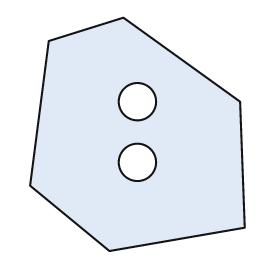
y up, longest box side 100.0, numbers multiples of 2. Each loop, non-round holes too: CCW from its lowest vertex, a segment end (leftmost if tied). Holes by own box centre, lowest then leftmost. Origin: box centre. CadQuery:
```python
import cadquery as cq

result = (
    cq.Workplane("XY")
    .moveTo(-12.0, -50.0)
    .lineTo(46.0, -40.0)
    .lineTo(44.0, 14.0)
    .lineTo(-6.0, 50.0)
    .lineTo(-38.0, 40.0)
    .lineTo(-46.0, -22.0)
    .close()
    .moveTo(0.0, -12.0)
    .circle(8.0)
    .moveTo(0.0, 14.0)
    .circle(8.0)
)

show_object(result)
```